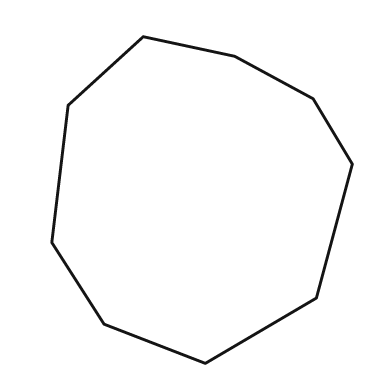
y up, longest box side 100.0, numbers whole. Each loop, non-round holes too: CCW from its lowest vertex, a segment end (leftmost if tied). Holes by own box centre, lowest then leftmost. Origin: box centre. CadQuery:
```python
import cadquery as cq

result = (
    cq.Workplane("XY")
    .moveTo(1.0, -50.0)
    .lineTo(35.0, -30.0)
    .lineTo(46.0, 11.0)
    .lineTo(34.0, 31.0)
    .lineTo(10.0, 44.0)
    .lineTo(-18.0, 50.0)
    .lineTo(-41.0, 29.0)
    .lineTo(-46.0, -13.0)
    .lineTo(-30.0, -38.0)
    .close()
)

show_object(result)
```